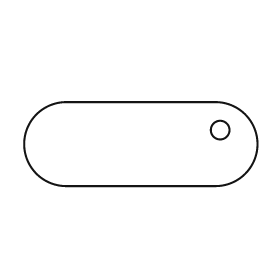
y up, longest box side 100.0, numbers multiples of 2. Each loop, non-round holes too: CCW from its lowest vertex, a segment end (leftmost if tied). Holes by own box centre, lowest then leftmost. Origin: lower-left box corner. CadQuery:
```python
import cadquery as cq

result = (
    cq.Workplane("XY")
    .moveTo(18.0, 0.0)
    .lineTo(82.0, 0.0)
    .threePointArc((100.0, 18.0), (82.0, 36.0))
    .lineTo(18.0, 36.0)
    .threePointArc((0.0, 18.0), (18.0, 0.0))
    .close()
    .moveTo(84.0, 24.0)
    .circle(4.0)
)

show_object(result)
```